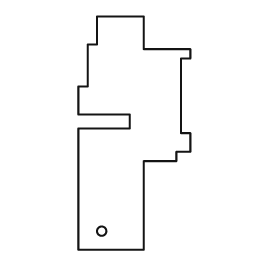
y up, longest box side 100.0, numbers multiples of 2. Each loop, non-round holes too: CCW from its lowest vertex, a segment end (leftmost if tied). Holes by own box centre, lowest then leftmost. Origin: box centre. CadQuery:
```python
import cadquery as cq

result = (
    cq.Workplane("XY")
    .moveTo(-24.0, -50.0)
    .lineTo(4.0, -50.0)
    .lineTo(4.0, -12.0)
    .lineTo(18.0, -12.0)
    .lineTo(18.0, -8.0)
    .lineTo(24.0, -8.0)
    .lineTo(24.0, 0.0)
    .lineTo(20.0, 0.0)
    .lineTo(20.0, 32.0)
    .lineTo(24.0, 32.0)
    .lineTo(24.0, 36.0)
    .lineTo(4.0, 36.0)
    .lineTo(4.0, 50.0)
    .lineTo(-16.0, 50.0)
    .lineTo(-16.0, 38.0)
    .lineTo(-20.0, 38.0)
    .lineTo(-20.0, 20.0)
    .lineTo(-24.0, 20.0)
    .lineTo(-24.0, 8.0)
    .lineTo(-2.0, 8.0)
    .lineTo(-2.0, 2.0)
    .lineTo(-24.0, 2.0)
    .close()
    .moveTo(-14.0, -42.0)
    .circle(2.0)
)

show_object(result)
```